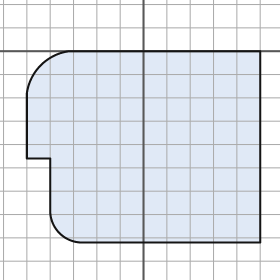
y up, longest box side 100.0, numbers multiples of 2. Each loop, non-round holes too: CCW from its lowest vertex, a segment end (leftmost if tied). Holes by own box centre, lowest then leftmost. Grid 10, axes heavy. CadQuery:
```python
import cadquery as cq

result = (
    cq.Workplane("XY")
    .moveTo(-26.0, -82.0)
    .lineTo(50.0, -82.0)
    .lineTo(50.0, 0.0)
    .lineTo(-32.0, 0.0)
    .threePointArc((-44.0, -6.0), (-50.0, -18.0))
    .lineTo(-50.0, -46.0)
    .lineTo(-40.0, -46.0)
    .lineTo(-40.0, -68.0)
    .threePointArc((-36.0, -78.0), (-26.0, -82.0))
    .close()
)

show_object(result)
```